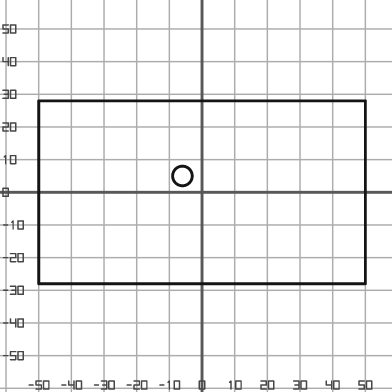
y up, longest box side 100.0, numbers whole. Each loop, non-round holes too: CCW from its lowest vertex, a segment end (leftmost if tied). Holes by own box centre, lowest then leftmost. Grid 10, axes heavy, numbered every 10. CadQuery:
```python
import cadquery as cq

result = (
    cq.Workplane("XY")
    .moveTo(-50.0, -28.0)
    .lineTo(50.0, -28.0)
    .lineTo(50.0, 28.0)
    .lineTo(-50.0, 28.0)
    .close()
    .moveTo(-6.0, 5.0)
    .circle(3.0)
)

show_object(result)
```